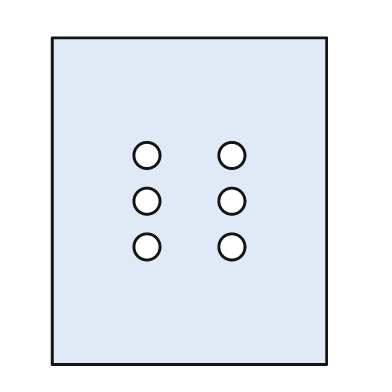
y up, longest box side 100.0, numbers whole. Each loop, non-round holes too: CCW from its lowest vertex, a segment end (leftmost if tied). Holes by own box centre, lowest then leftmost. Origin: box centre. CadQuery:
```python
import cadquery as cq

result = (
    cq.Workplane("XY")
    .moveTo(-42.0, -50.0)
    .lineTo(42.0, -50.0)
    .lineTo(42.0, 50.0)
    .lineTo(-42.0, 50.0)
    .close()
    .moveTo(-13.0, -14.0)
    .circle(4.0)
    .moveTo(13.0, -14.0)
    .circle(4.0)
    .moveTo(-13.0, 0.0)
    .circle(4.0)
    .moveTo(13.0, 0.0)
    .circle(4.0)
    .moveTo(-13.0, 14.0)
    .circle(4.0)
    .moveTo(13.0, 14.0)
    .circle(4.0)
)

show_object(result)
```